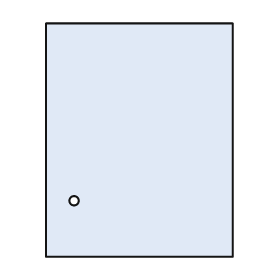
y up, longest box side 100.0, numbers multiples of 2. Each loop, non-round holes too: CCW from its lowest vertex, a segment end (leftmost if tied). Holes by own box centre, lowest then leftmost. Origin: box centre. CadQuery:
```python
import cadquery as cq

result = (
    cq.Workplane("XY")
    .moveTo(-40.0, -50.0)
    .lineTo(40.0, -50.0)
    .lineTo(40.0, 50.0)
    .lineTo(-40.0, 50.0)
    .close()
    .moveTo(-28.0, -26.0)
    .circle(2.0)
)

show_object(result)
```